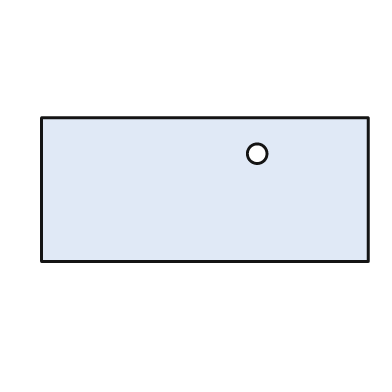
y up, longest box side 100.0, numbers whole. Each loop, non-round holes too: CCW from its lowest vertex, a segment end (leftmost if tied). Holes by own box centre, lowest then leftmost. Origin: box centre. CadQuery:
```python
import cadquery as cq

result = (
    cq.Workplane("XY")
    .moveTo(-50.0, -22.0)
    .lineTo(50.0, -22.0)
    .lineTo(50.0, 22.0)
    .lineTo(-50.0, 22.0)
    .close()
    .moveTo(16.0, 11.0)
    .circle(3.0)
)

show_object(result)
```